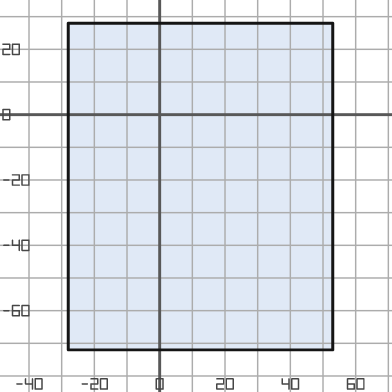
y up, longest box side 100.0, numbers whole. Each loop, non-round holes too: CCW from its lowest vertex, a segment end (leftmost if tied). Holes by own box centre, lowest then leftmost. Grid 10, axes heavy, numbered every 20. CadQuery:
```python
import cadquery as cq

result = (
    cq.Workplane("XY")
    .moveTo(-28.0, -72.0)
    .lineTo(53.0, -72.0)
    .lineTo(53.0, 28.0)
    .lineTo(-28.0, 28.0)
    .close()
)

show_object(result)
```